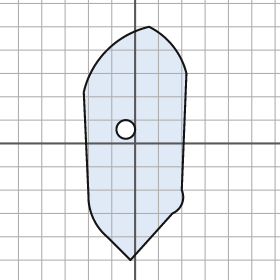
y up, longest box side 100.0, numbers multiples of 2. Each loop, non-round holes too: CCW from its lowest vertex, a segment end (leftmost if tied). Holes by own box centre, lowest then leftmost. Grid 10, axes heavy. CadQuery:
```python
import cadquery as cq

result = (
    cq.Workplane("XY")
    .moveTo(-2.0, -50.0)
    .lineTo(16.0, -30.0)
    .threePointArc((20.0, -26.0), (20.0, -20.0))
    .lineTo(22.0, 30.0)
    .threePointArc((16.0, 42.0), (6.0, 50.0))
    .threePointArc((-12.0, 40.0), (-22.0, 22.0))
    .lineTo(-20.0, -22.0)
    .threePointArc((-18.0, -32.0), (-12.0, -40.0))
    .close()
    .moveTo(-4.0, 6.0)
    .circle(4.0)
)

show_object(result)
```